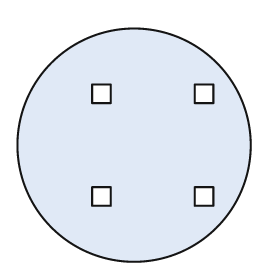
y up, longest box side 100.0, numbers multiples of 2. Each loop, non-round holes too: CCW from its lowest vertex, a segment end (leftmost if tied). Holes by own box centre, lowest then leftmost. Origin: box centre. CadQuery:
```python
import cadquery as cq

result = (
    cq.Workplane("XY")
    .moveTo(0.0, 0.0)
    .circle(50.0)
    .moveTo(-18.0, -26.0)
    .lineTo(-10.0, -26.0)
    .lineTo(-10.0, -18.0)
    .lineTo(-18.0, -18.0)
    .close()
    .moveTo(26.0, -26.0)
    .lineTo(34.0, -26.0)
    .lineTo(34.0, -18.0)
    .lineTo(26.0, -18.0)
    .close()
    .moveTo(-18.0, 18.0)
    .lineTo(-10.0, 18.0)
    .lineTo(-10.0, 26.0)
    .lineTo(-18.0, 26.0)
    .close()
    .moveTo(26.0, 18.0)
    .lineTo(34.0, 18.0)
    .lineTo(34.0, 26.0)
    .lineTo(26.0, 26.0)
    .close()
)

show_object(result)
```